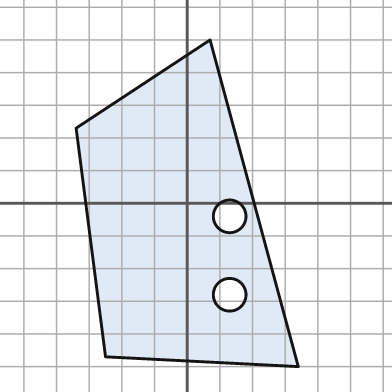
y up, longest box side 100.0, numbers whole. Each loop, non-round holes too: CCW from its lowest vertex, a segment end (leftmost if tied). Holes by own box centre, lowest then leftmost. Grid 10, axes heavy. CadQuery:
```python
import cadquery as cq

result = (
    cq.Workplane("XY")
    .moveTo(34.0, -50.0)
    .lineTo(7.0, 50.0)
    .lineTo(-34.0, 23.0)
    .lineTo(-25.0, -47.0)
    .close()
    .moveTo(13.0, -28.0)
    .circle(5.0)
    .moveTo(13.0, -4.0)
    .circle(5.0)
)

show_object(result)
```